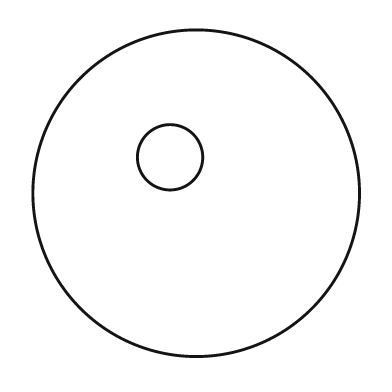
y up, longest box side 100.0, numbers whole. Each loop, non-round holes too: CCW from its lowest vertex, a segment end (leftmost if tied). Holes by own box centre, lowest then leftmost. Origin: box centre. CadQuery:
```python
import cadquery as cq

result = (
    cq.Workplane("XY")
    .moveTo(0.0, 0.0)
    .circle(50.0)
    .moveTo(-8.0, 11.0)
    .circle(10.0)
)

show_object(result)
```